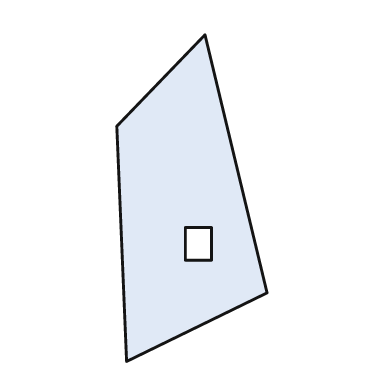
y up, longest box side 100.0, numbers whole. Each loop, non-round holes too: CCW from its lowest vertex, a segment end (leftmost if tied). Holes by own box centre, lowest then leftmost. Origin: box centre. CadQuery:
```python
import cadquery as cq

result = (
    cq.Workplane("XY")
    .moveTo(-20.0, -50.0)
    .lineTo(23.0, -29.0)
    .lineTo(4.0, 50.0)
    .lineTo(-23.0, 22.0)
    .close()
    .moveTo(-2.0, -19.0)
    .lineTo(6.0, -19.0)
    .lineTo(6.0, -9.0)
    .lineTo(-2.0, -9.0)
    .close()
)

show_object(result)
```